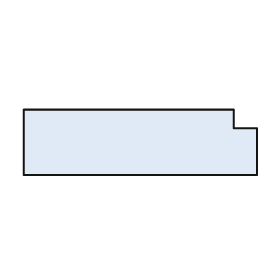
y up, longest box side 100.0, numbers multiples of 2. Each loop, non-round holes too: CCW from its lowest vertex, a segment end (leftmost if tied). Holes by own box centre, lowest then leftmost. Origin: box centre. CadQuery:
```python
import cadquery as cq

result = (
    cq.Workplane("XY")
    .moveTo(-50.0, -14.0)
    .lineTo(50.0, -14.0)
    .lineTo(50.0, 6.0)
    .lineTo(40.0, 6.0)
    .lineTo(40.0, 14.0)
    .lineTo(-50.0, 14.0)
    .close()
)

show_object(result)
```